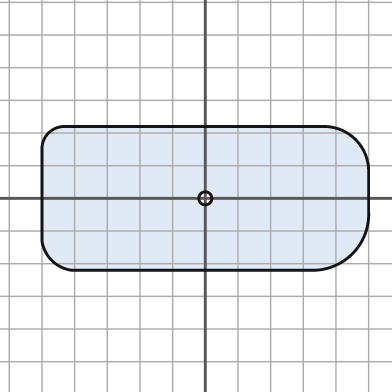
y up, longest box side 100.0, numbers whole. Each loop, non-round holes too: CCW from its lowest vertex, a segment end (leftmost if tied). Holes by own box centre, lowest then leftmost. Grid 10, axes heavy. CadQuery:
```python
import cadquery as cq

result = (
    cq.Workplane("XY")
    .moveTo(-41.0, -22.0)
    .lineTo(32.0, -22.0)
    .threePointArc((45.0, -17.0), (50.0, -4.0))
    .lineTo(50.0, 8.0)
    .threePointArc((46.0, 18.0), (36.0, 22.0))
    .lineTo(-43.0, 22.0)
    .threePointArc((-48.0, 20.0), (-50.0, 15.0))
    .lineTo(-50.0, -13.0)
    .threePointArc((-47.0, -19.0), (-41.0, -22.0))
    .close()
    .moveTo(0.0, 0.0)
    .circle(2.0)
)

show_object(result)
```